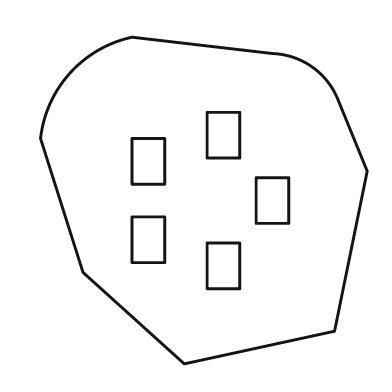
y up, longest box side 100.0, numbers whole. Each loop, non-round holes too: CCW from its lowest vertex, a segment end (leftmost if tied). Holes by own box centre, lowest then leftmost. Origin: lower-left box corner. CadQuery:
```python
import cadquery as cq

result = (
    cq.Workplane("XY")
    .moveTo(44.0, 0.0)
    .lineTo(90.0, 10.0)
    .lineTo(100.0, 59.0)
    .lineTo(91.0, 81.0)
    .threePointArc((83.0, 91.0), (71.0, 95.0))
    .lineTo(28.0, 100.0)
    .threePointArc((9.0, 89.0), (0.0, 69.0))
    .lineTo(13.0, 28.0)
    .close()
    .moveTo(51.0, 23.0)
    .lineTo(61.0, 23.0)
    .lineTo(61.0, 37.0)
    .lineTo(51.0, 37.0)
    .close()
    .moveTo(28.0, 31.0)
    .lineTo(38.0, 31.0)
    .lineTo(38.0, 45.0)
    .lineTo(28.0, 45.0)
    .close()
    .moveTo(66.0, 43.0)
    .lineTo(76.0, 43.0)
    .lineTo(76.0, 57.0)
    .lineTo(66.0, 57.0)
    .close()
    .moveTo(28.0, 55.0)
    .lineTo(38.0, 55.0)
    .lineTo(38.0, 69.0)
    .lineTo(28.0, 69.0)
    .close()
    .moveTo(51.0, 63.0)
    .lineTo(61.0, 63.0)
    .lineTo(61.0, 77.0)
    .lineTo(51.0, 77.0)
    .close()
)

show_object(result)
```